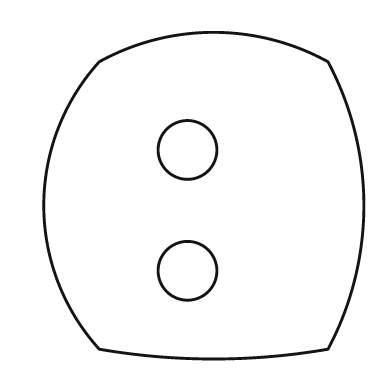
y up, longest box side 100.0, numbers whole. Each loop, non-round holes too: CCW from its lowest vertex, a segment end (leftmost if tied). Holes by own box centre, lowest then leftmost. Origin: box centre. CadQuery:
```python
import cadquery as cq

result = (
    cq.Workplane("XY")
    .moveTo(-32.0, -47.0)
    .threePointArc((3.0, -50.0), (38.0, -47.0))
    .threePointArc((49.0, -3.0), (38.0, 41.0))
    .threePointArc((3.0, 50.0), (-32.0, 41.0))
    .threePointArc((-49.0, -3.0), (-32.0, -47.0))
    .close()
    .moveTo(-5.0, -23.0)
    .circle(9.0)
    .moveTo(-5.0, 14.0)
    .circle(9.0)
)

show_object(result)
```